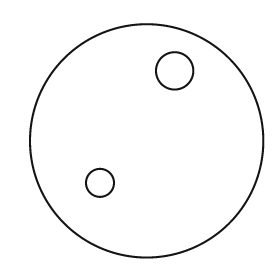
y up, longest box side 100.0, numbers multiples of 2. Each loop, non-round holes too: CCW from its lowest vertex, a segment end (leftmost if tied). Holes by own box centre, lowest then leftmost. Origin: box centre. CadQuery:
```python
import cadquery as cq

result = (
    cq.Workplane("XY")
    .moveTo(0.0, 0.0)
    .circle(50.0)
    .moveTo(-20.0, -18.0)
    .circle(6.0)
    .moveTo(12.0, 30.0)
    .circle(8.0)
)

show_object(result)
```